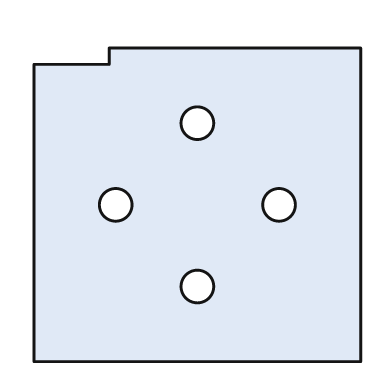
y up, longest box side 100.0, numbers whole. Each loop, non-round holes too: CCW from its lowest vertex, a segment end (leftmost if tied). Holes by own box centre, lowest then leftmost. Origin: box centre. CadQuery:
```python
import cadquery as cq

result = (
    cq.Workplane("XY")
    .moveTo(-50.0, -48.0)
    .lineTo(50.0, -48.0)
    .lineTo(50.0, 48.0)
    .lineTo(-27.0, 48.0)
    .lineTo(-27.0, 43.0)
    .lineTo(-50.0, 43.0)
    .close()
    .moveTo(0.0, -25.0)
    .circle(5.0)
    .moveTo(-25.0, 0.0)
    .circle(5.0)
    .moveTo(25.0, 0.0)
    .circle(5.0)
    .moveTo(0.0, 25.0)
    .circle(5.0)
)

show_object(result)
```